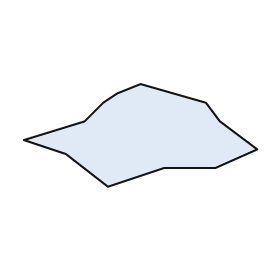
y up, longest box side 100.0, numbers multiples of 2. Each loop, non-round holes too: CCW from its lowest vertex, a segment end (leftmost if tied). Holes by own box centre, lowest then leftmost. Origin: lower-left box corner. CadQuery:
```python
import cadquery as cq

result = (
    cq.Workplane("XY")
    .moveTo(36.0, 0.0)
    .lineTo(60.0, 8.0)
    .lineTo(82.0, 8.0)
    .lineTo(100.0, 16.0)
    .lineTo(84.0, 28.0)
    .lineTo(78.0, 36.0)
    .lineTo(50.0, 44.0)
    .lineTo(40.0, 40.0)
    .lineTo(34.0, 36.0)
    .lineTo(26.0, 28.0)
    .lineTo(0.0, 20.0)
    .lineTo(18.0, 14.0)
    .close()
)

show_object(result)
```